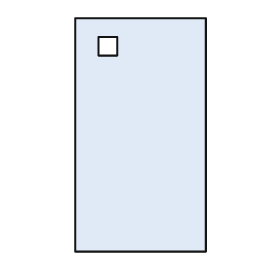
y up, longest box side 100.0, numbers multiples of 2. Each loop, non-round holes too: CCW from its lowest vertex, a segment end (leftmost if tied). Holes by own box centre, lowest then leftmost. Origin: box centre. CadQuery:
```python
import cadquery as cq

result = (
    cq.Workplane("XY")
    .moveTo(-28.0, -50.0)
    .lineTo(28.0, -50.0)
    .lineTo(28.0, 50.0)
    .lineTo(-28.0, 50.0)
    .close()
    .moveTo(-18.0, 34.0)
    .lineTo(-10.0, 34.0)
    .lineTo(-10.0, 42.0)
    .lineTo(-18.0, 42.0)
    .close()
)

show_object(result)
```